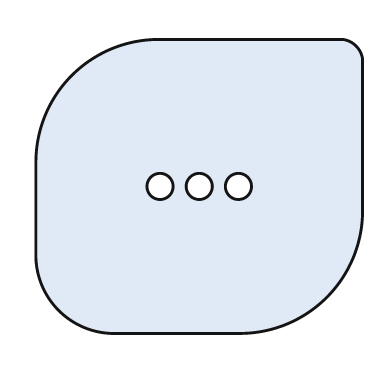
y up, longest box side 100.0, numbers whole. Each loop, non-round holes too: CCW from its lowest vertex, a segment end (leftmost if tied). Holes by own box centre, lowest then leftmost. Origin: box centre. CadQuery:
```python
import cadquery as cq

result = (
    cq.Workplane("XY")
    .moveTo(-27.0, -45.0)
    .lineTo(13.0, -45.0)
    .threePointArc((39.0, -34.0), (50.0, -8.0))
    .lineTo(50.0, 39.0)
    .threePointArc((48.0, 43.0), (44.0, 45.0))
    .lineTo(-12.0, 45.0)
    .threePointArc((-39.0, 34.0), (-50.0, 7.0))
    .lineTo(-50.0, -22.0)
    .threePointArc((-43.0, -38.0), (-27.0, -45.0))
    .close()
    .moveTo(-12.0, 0.0)
    .circle(4.0)
    .moveTo(0.0, 0.0)
    .circle(4.0)
    .moveTo(12.0, 0.0)
    .circle(4.0)
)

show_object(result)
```